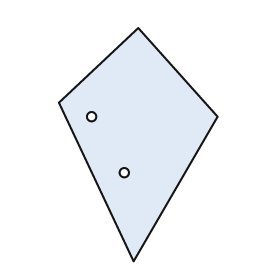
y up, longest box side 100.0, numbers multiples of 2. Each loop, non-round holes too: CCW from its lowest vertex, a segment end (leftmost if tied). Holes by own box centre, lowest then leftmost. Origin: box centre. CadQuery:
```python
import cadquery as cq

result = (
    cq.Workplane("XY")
    .moveTo(-2.0, -50.0)
    .lineTo(34.0, 12.0)
    .lineTo(0.0, 50.0)
    .lineTo(-34.0, 18.0)
    .close()
    .moveTo(-6.0, -12.0)
    .circle(2.0)
    .moveTo(-20.0, 12.0)
    .circle(2.0)
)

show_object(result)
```